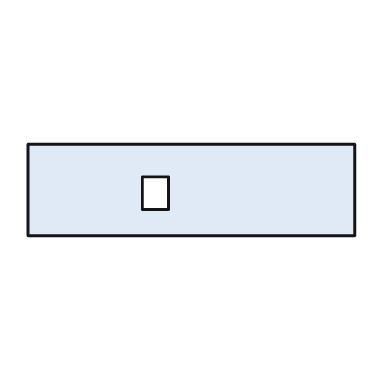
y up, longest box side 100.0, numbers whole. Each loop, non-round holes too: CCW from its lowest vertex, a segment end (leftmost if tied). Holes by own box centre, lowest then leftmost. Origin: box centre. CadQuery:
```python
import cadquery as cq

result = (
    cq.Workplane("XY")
    .moveTo(-50.0, -14.0)
    .lineTo(50.0, -14.0)
    .lineTo(50.0, 14.0)
    .lineTo(-50.0, 14.0)
    .close()
    .moveTo(-15.0, -6.0)
    .lineTo(-7.0, -6.0)
    .lineTo(-7.0, 4.0)
    .lineTo(-15.0, 4.0)
    .close()
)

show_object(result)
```